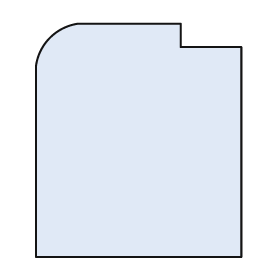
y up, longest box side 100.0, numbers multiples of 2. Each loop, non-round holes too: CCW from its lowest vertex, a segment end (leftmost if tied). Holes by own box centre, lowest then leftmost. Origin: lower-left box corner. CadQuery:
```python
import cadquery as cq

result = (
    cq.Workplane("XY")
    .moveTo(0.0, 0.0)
    .lineTo(88.0, 0.0)
    .lineTo(88.0, 90.0)
    .lineTo(62.0, 90.0)
    .lineTo(62.0, 100.0)
    .lineTo(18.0, 100.0)
    .threePointArc((6.0, 94.0), (0.0, 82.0))
    .close()
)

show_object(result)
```